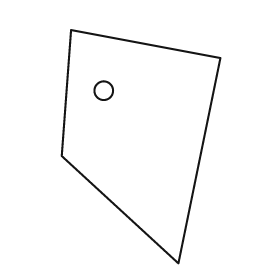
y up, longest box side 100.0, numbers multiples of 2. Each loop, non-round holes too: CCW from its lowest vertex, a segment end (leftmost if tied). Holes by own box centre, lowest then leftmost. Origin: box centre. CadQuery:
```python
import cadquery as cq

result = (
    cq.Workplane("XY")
    .moveTo(16.0, -50.0)
    .lineTo(34.0, 38.0)
    .lineTo(-30.0, 50.0)
    .lineTo(-34.0, -4.0)
    .close()
    .moveTo(-16.0, 24.0)
    .circle(4.0)
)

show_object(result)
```